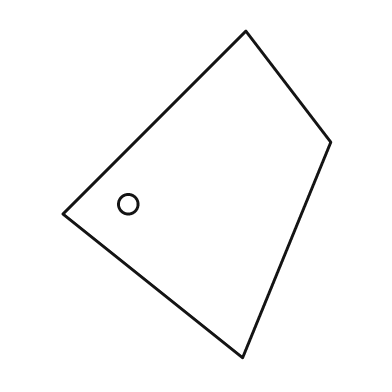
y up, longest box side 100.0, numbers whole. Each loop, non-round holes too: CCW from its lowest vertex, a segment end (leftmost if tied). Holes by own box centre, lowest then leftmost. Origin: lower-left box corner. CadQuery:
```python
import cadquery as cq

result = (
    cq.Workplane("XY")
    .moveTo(55.0, 0.0)
    .lineTo(82.0, 66.0)
    .lineTo(56.0, 100.0)
    .lineTo(0.0, 44.0)
    .close()
    .moveTo(20.0, 47.0)
    .circle(3.0)
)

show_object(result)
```